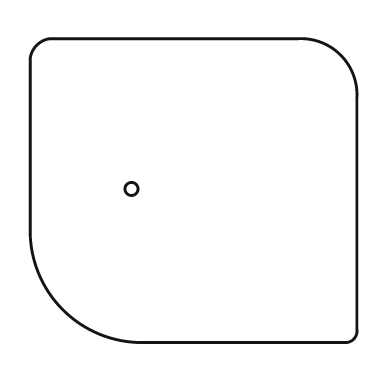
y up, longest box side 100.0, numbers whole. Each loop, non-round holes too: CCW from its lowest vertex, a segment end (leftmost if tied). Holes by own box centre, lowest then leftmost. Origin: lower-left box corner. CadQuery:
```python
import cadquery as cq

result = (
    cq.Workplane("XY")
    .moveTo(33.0, 0.0)
    .lineTo(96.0, 0.0)
    .threePointArc((99.0, 1.0), (100.0, 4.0))
    .lineTo(100.0, 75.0)
    .threePointArc((95.0, 88.0), (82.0, 93.0))
    .lineTo(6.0, 93.0)
    .threePointArc((2.0, 91.0), (0.0, 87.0))
    .lineTo(0.0, 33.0)
    .threePointArc((10.0, 10.0), (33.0, 0.0))
    .close()
    .moveTo(31.0, 47.0)
    .circle(2.0)
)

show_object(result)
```